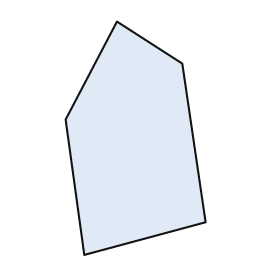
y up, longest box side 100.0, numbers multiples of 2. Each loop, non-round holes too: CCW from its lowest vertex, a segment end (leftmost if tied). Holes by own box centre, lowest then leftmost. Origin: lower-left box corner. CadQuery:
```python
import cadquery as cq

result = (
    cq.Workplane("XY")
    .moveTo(8.0, 0.0)
    .lineTo(60.0, 14.0)
    .lineTo(50.0, 82.0)
    .lineTo(22.0, 100.0)
    .lineTo(0.0, 58.0)
    .close()
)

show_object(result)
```